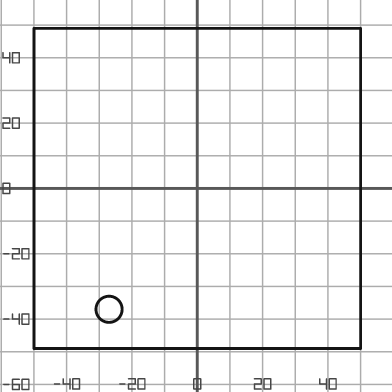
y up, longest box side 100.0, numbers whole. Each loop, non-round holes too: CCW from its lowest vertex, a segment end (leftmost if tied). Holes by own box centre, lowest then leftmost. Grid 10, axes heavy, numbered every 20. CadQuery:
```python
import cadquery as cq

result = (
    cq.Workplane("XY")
    .moveTo(-50.0, -49.0)
    .lineTo(50.0, -49.0)
    .lineTo(50.0, 49.0)
    .lineTo(-50.0, 49.0)
    .close()
    .moveTo(-27.0, -37.0)
    .circle(4.0)
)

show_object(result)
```